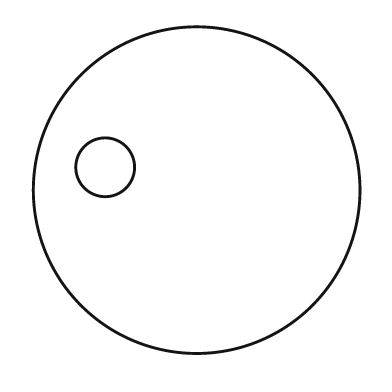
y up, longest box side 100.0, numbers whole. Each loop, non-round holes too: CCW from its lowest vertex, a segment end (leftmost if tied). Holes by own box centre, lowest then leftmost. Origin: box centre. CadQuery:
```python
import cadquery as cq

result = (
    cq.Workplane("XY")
    .moveTo(0.0, 0.0)
    .circle(50.0)
    .moveTo(-28.0, 7.0)
    .circle(9.0)
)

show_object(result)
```